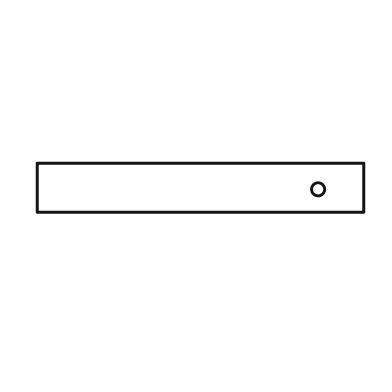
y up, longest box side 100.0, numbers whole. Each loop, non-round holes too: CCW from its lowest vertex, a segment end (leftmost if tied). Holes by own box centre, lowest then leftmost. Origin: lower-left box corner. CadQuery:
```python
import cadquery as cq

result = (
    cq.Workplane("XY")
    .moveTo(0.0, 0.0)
    .lineTo(100.0, 0.0)
    .lineTo(100.0, 15.0)
    .lineTo(0.0, 15.0)
    .close()
    .moveTo(86.0, 7.0)
    .circle(2.0)
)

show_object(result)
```